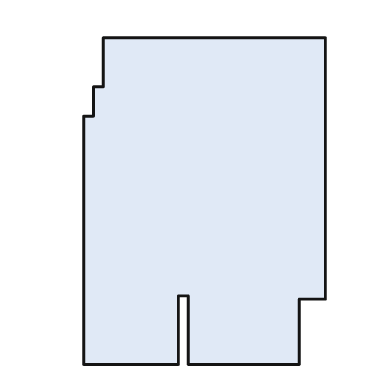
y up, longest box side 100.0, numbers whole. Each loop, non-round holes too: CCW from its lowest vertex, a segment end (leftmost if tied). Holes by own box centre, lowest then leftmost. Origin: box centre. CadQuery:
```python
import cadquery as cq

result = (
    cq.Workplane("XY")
    .moveTo(-37.0, -50.0)
    .lineTo(-8.0, -50.0)
    .lineTo(-8.0, -29.0)
    .lineTo(-5.0, -29.0)
    .lineTo(-5.0, -50.0)
    .lineTo(29.0, -50.0)
    .lineTo(29.0, -30.0)
    .lineTo(37.0, -30.0)
    .lineTo(37.0, 50.0)
    .lineTo(-31.0, 50.0)
    .lineTo(-31.0, 35.0)
    .lineTo(-34.0, 35.0)
    .lineTo(-34.0, 26.0)
    .lineTo(-37.0, 26.0)
    .close()
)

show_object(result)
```